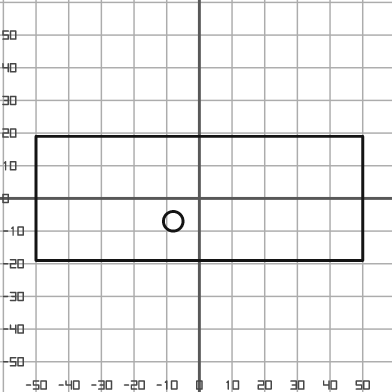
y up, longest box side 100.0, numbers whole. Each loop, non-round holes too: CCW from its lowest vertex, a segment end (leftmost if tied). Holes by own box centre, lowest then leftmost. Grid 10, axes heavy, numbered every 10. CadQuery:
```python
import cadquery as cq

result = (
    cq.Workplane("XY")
    .moveTo(-50.0, -19.0)
    .lineTo(50.0, -19.0)
    .lineTo(50.0, 19.0)
    .lineTo(-50.0, 19.0)
    .close()
    .moveTo(-8.0, -7.0)
    .circle(3.0)
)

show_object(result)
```